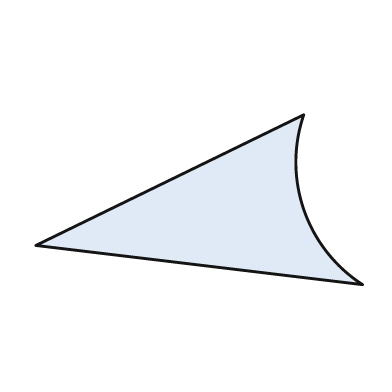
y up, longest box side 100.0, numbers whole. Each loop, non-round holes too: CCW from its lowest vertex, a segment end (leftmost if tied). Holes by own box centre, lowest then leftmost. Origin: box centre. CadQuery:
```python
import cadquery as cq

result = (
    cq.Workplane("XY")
    .moveTo(50.0, -26.0)
    .threePointArc((32.0, -3.0), (32.0, 26.0))
    .lineTo(-50.0, -14.0)
    .close()
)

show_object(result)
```